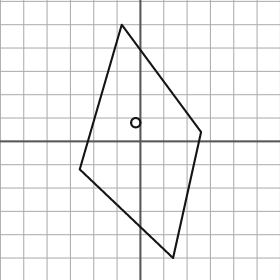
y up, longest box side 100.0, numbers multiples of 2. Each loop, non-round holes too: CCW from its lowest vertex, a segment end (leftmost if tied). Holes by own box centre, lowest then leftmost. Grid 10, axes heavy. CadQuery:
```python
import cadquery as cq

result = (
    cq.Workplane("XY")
    .moveTo(14.0, -50.0)
    .lineTo(26.0, 4.0)
    .lineTo(-8.0, 50.0)
    .lineTo(-26.0, -12.0)
    .close()
    .moveTo(-2.0, 8.0)
    .circle(2.0)
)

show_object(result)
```